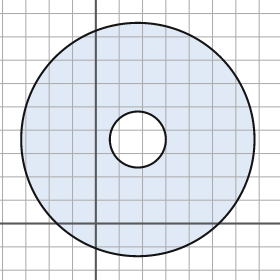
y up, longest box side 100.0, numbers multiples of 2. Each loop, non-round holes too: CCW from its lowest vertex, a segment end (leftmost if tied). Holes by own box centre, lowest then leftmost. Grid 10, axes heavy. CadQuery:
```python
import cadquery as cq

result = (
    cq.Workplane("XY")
    .moveTo(18.0, 36.0)
    .circle(50.0)
    .moveTo(18.0, 36.0)
    .circle(12.0)
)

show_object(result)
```